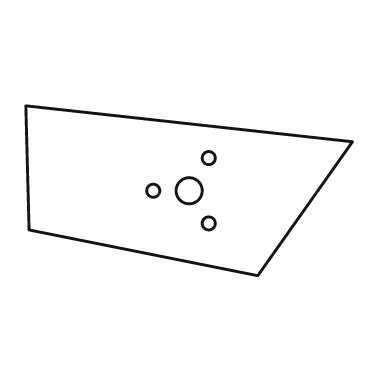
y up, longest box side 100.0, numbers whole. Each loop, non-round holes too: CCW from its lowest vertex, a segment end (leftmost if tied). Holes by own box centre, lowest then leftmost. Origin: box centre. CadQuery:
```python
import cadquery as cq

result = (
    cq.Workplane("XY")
    .moveTo(21.0, -26.0)
    .lineTo(50.0, 15.0)
    .lineTo(-50.0, 26.0)
    .lineTo(-49.0, -12.0)
    .close()
    .moveTo(6.0, -10.0)
    .circle(2.0)
    .moveTo(-11.0, 0.0)
    .circle(2.0)
    .moveTo(0.0, 0.0)
    .circle(4.0)
    .moveTo(6.0, 10.0)
    .circle(2.0)
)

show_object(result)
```